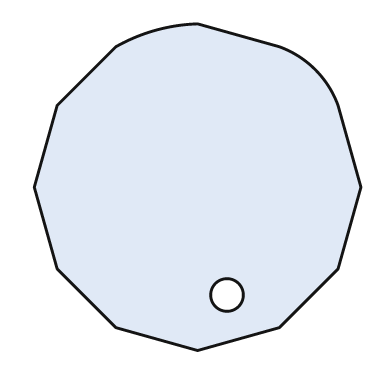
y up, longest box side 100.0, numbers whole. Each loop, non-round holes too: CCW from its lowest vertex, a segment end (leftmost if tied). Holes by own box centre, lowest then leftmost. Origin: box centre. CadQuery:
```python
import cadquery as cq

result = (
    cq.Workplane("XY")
    .moveTo(0.0, -50.0)
    .lineTo(25.0, -43.0)
    .lineTo(43.0, -25.0)
    .lineTo(50.0, 0.0)
    .lineTo(43.0, 25.0)
    .threePointArc((36.0, 36.0), (25.0, 43.0))
    .lineTo(0.0, 50.0)
    .threePointArc((-13.0, 48.0), (-25.0, 43.0))
    .lineTo(-43.0, 25.0)
    .lineTo(-50.0, 0.0)
    .lineTo(-43.0, -25.0)
    .lineTo(-25.0, -43.0)
    .close()
    .moveTo(9.0, -33.0)
    .circle(5.0)
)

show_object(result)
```